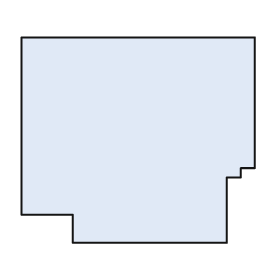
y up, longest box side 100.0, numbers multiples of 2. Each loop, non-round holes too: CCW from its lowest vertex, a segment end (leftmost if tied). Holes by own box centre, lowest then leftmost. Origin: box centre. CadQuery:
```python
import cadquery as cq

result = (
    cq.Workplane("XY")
    .moveTo(-28.0, -44.0)
    .lineTo(38.0, -44.0)
    .lineTo(38.0, -16.0)
    .lineTo(44.0, -16.0)
    .lineTo(44.0, -12.0)
    .lineTo(50.0, -12.0)
    .lineTo(50.0, 44.0)
    .lineTo(-50.0, 44.0)
    .lineTo(-50.0, -32.0)
    .lineTo(-28.0, -32.0)
    .close()
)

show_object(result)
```